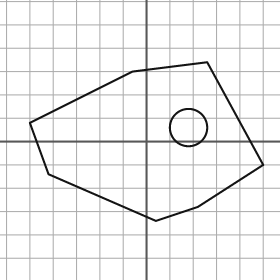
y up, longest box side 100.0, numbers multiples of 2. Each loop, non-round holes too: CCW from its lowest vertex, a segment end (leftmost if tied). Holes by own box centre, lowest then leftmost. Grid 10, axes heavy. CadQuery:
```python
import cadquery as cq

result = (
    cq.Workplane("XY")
    .moveTo(4.0, -34.0)
    .lineTo(22.0, -28.0)
    .lineTo(50.0, -10.0)
    .lineTo(26.0, 34.0)
    .lineTo(-6.0, 30.0)
    .lineTo(-50.0, 8.0)
    .lineTo(-42.0, -14.0)
    .close()
    .moveTo(18.0, 6.0)
    .circle(8.0)
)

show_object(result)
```